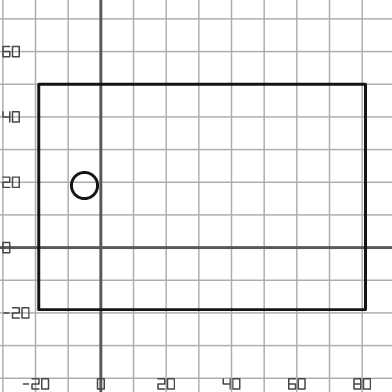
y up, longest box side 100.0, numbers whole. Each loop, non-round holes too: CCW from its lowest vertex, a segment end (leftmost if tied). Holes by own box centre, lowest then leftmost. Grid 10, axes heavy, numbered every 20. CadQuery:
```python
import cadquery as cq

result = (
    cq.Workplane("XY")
    .moveTo(-19.0, -19.0)
    .lineTo(81.0, -19.0)
    .lineTo(81.0, 50.0)
    .lineTo(-19.0, 50.0)
    .close()
    .moveTo(-5.0, 19.0)
    .circle(4.0)
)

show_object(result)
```